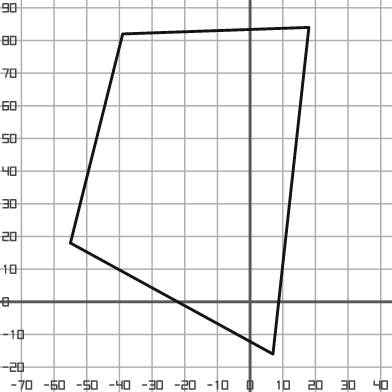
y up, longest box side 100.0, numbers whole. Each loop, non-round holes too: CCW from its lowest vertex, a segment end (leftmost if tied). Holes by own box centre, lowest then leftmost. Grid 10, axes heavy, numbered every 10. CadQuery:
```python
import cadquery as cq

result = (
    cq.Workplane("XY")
    .moveTo(7.0, -16.0)
    .lineTo(18.0, 84.0)
    .lineTo(-39.0, 82.0)
    .lineTo(-55.0, 18.0)
    .close()
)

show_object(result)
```